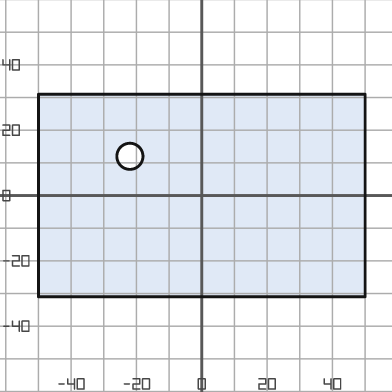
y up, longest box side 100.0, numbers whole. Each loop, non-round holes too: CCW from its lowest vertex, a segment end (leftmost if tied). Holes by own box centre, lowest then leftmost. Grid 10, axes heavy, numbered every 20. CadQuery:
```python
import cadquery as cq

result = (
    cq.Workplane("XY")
    .moveTo(-50.0, -31.0)
    .lineTo(50.0, -31.0)
    .lineTo(50.0, 31.0)
    .lineTo(-50.0, 31.0)
    .close()
    .moveTo(-22.0, 12.0)
    .circle(4.0)
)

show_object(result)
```